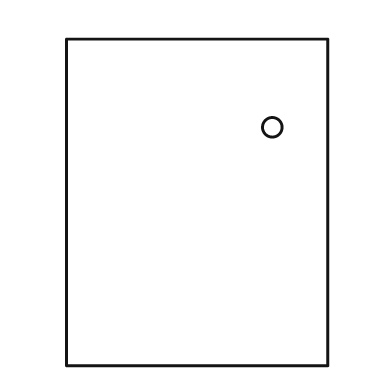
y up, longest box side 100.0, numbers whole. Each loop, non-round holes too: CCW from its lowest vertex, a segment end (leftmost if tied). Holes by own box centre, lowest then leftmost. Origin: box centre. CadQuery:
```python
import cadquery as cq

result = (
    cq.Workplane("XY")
    .moveTo(-40.0, -50.0)
    .lineTo(40.0, -50.0)
    .lineTo(40.0, 50.0)
    .lineTo(-40.0, 50.0)
    .close()
    .moveTo(23.0, 23.0)
    .circle(3.0)
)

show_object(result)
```